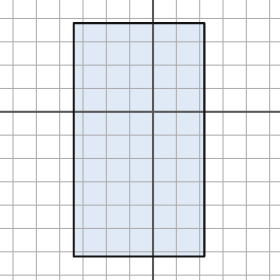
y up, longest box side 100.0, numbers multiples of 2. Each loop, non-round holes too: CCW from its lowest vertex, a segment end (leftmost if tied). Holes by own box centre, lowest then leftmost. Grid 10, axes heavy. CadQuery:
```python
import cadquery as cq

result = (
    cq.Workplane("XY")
    .moveTo(-34.0, -62.0)
    .lineTo(22.0, -62.0)
    .lineTo(22.0, 38.0)
    .lineTo(-34.0, 38.0)
    .close()
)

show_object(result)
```